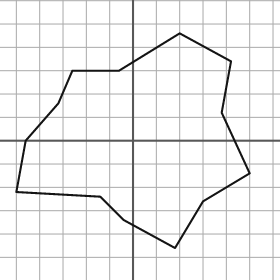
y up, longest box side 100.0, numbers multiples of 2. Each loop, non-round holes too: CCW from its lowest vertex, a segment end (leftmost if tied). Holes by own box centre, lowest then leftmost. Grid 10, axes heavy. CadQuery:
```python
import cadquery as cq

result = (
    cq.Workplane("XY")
    .moveTo(18.0, -46.0)
    .lineTo(30.0, -26.0)
    .lineTo(50.0, -14.0)
    .lineTo(38.0, 12.0)
    .lineTo(42.0, 34.0)
    .lineTo(20.0, 46.0)
    .lineTo(-6.0, 30.0)
    .lineTo(-26.0, 30.0)
    .lineTo(-32.0, 16.0)
    .lineTo(-46.0, 0.0)
    .lineTo(-50.0, -22.0)
    .lineTo(-14.0, -24.0)
    .lineTo(-4.0, -34.0)
    .close()
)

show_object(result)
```